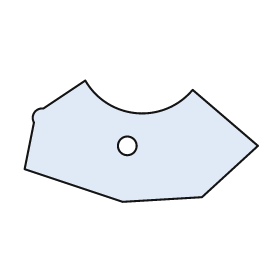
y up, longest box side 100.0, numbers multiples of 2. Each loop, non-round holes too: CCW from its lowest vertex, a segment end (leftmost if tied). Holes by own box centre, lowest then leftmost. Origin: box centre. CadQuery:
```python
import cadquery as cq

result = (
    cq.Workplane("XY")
    .moveTo(-8.0, -26.0)
    .lineTo(26.0, -24.0)
    .lineTo(50.0, -2.0)
    .lineTo(22.0, 22.0)
    .threePointArc((-2.0, 12.0), (-24.0, 26.0))
    .lineTo(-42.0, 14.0)
    .threePointArc((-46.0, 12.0), (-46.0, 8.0))
    .lineTo(-50.0, -12.0)
    .close()
    .moveTo(-6.0, -2.0)
    .circle(4.0)
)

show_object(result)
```